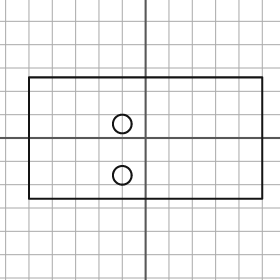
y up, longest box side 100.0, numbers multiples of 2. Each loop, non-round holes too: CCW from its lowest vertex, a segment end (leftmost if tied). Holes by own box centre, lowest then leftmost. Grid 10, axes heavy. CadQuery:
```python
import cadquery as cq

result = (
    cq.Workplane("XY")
    .moveTo(-50.0, -26.0)
    .lineTo(50.0, -26.0)
    .lineTo(50.0, 26.0)
    .lineTo(-50.0, 26.0)
    .close()
    .moveTo(-10.0, -16.0)
    .circle(4.0)
    .moveTo(-10.0, 6.0)
    .circle(4.0)
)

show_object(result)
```